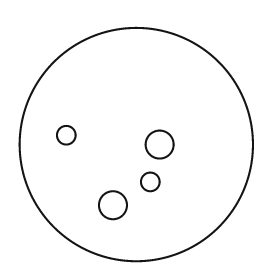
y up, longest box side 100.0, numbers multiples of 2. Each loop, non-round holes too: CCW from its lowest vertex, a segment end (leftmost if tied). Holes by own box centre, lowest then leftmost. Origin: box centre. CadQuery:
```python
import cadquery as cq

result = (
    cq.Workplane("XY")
    .moveTo(0.0, 0.0)
    .circle(50.0)
    .moveTo(-10.0, -26.0)
    .circle(6.0)
    .moveTo(6.0, -16.0)
    .circle(4.0)
    .moveTo(10.0, 0.0)
    .circle(6.0)
    .moveTo(-30.0, 4.0)
    .circle(4.0)
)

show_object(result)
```